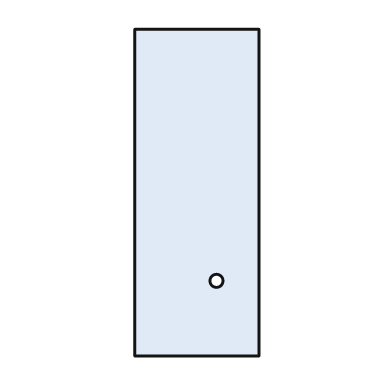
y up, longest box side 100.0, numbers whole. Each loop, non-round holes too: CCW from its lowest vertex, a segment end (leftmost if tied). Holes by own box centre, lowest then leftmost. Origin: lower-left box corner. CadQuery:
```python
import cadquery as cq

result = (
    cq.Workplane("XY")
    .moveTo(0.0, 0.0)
    .lineTo(38.0, 0.0)
    .lineTo(38.0, 100.0)
    .lineTo(0.0, 100.0)
    .close()
    .moveTo(25.0, 23.0)
    .circle(2.0)
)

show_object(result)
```